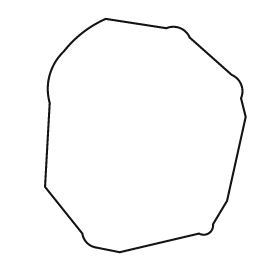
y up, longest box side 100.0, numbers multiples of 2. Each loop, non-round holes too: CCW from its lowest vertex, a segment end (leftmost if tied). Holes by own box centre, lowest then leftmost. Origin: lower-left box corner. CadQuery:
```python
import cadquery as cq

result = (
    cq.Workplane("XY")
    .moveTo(32.0, 0.0)
    .lineTo(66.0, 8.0)
    .threePointArc((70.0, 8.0), (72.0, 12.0))
    .lineTo(78.0, 22.0)
    .lineTo(86.0, 58.0)
    .lineTo(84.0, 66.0)
    .threePointArc((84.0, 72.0), (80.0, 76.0))
    .lineTo(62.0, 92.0)
    .threePointArc((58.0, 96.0), (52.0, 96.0))
    .lineTo(26.0, 100.0)
    .threePointArc((16.0, 94.0), (8.0, 86.0))
    .threePointArc((2.0, 76.0), (2.0, 64.0))
    .lineTo(0.0, 28.0)
    .lineTo(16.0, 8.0)
    .threePointArc((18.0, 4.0), (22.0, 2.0))
    .close()
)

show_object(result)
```